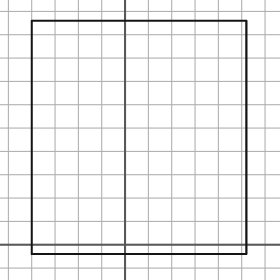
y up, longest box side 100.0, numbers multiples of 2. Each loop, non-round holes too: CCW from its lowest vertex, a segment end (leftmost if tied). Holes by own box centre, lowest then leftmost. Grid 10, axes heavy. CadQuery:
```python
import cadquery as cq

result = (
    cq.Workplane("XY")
    .moveTo(-40.0, -4.0)
    .lineTo(52.0, -4.0)
    .lineTo(52.0, 96.0)
    .lineTo(-40.0, 96.0)
    .close()
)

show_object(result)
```